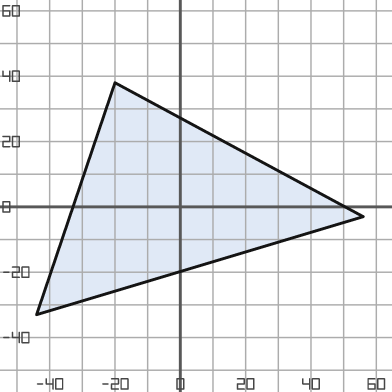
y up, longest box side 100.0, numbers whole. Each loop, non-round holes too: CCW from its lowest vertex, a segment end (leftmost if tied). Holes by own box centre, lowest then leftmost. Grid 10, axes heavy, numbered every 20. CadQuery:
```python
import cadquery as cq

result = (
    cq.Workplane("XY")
    .moveTo(-44.0, -33.0)
    .lineTo(56.0, -3.0)
    .lineTo(-20.0, 38.0)
    .close()
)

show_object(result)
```